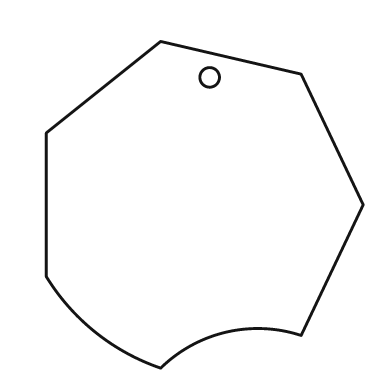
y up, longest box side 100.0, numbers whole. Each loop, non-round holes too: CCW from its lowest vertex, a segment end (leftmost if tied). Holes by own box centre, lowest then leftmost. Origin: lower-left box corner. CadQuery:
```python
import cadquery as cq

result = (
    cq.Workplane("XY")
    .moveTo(35.0, 0.0)
    .threePointArc((55.0, 11.0), (78.0, 10.0))
    .lineTo(97.0, 50.0)
    .lineTo(78.0, 90.0)
    .lineTo(35.0, 100.0)
    .lineTo(0.0, 72.0)
    .lineTo(0.0, 28.0)
    .threePointArc((15.0, 11.0), (35.0, 0.0))
    .close()
    .moveTo(50.0, 89.0)
    .circle(3.0)
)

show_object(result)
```